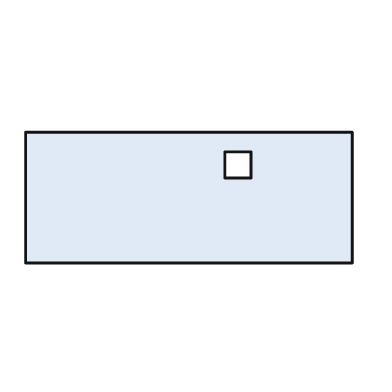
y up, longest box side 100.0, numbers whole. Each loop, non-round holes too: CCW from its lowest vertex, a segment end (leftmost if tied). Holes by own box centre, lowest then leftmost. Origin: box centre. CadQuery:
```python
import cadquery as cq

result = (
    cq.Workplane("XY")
    .moveTo(-50.0, -20.0)
    .lineTo(50.0, -20.0)
    .lineTo(50.0, 20.0)
    .lineTo(-50.0, 20.0)
    .close()
    .moveTo(11.0, 6.0)
    .lineTo(19.0, 6.0)
    .lineTo(19.0, 14.0)
    .lineTo(11.0, 14.0)
    .close()
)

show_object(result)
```